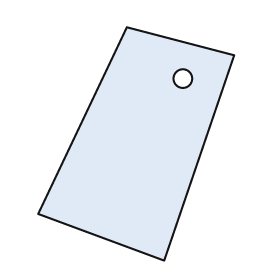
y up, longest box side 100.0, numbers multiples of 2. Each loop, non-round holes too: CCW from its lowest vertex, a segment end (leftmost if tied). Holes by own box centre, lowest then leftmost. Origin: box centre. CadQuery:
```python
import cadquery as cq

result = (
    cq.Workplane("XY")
    .moveTo(12.0, -50.0)
    .lineTo(42.0, 38.0)
    .lineTo(-4.0, 50.0)
    .lineTo(-42.0, -30.0)
    .close()
    .moveTo(20.0, 28.0)
    .circle(4.0)
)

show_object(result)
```